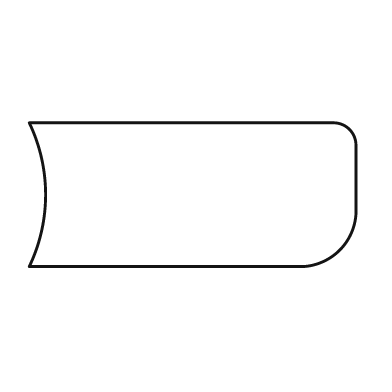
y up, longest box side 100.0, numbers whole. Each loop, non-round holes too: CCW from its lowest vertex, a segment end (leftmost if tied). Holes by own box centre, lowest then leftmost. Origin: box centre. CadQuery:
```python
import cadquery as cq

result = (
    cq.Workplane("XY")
    .moveTo(-50.0, -22.0)
    .lineTo(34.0, -22.0)
    .threePointArc((45.0, -17.0), (50.0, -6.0))
    .lineTo(50.0, 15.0)
    .threePointArc((48.0, 20.0), (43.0, 22.0))
    .lineTo(-50.0, 22.0)
    .threePointArc((-45.0, 0.0), (-50.0, -22.0))
    .close()
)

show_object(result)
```